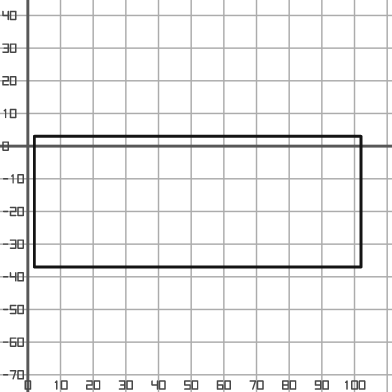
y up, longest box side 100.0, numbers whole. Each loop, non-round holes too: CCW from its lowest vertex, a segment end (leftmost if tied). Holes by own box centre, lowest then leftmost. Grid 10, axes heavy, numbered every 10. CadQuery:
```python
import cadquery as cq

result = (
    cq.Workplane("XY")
    .moveTo(2.0, -37.0)
    .lineTo(102.0, -37.0)
    .lineTo(102.0, 3.0)
    .lineTo(2.0, 3.0)
    .close()
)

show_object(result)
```